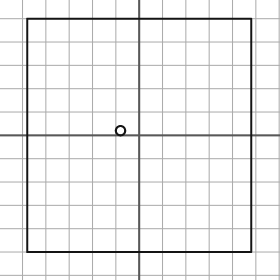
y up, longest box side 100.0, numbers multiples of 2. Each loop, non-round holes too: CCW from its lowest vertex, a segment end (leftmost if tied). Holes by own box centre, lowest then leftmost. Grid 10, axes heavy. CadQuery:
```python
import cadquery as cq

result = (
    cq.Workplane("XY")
    .moveTo(-48.0, -50.0)
    .lineTo(48.0, -50.0)
    .lineTo(48.0, 50.0)
    .lineTo(-48.0, 50.0)
    .close()
    .moveTo(-8.0, 2.0)
    .circle(2.0)
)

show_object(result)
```